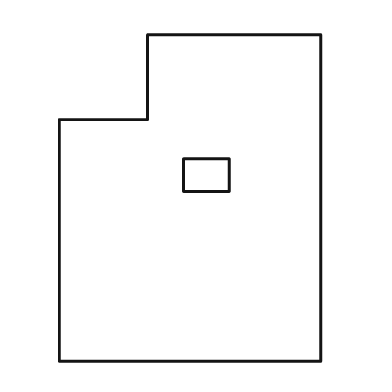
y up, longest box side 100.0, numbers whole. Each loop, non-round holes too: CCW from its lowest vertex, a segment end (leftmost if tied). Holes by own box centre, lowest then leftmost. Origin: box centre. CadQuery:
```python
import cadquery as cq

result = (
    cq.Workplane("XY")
    .moveTo(-40.0, -50.0)
    .lineTo(40.0, -50.0)
    .lineTo(40.0, 50.0)
    .lineTo(-13.0, 50.0)
    .lineTo(-13.0, 24.0)
    .lineTo(-40.0, 24.0)
    .close()
    .moveTo(-2.0, 2.0)
    .lineTo(12.0, 2.0)
    .lineTo(12.0, 12.0)
    .lineTo(-2.0, 12.0)
    .close()
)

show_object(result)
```